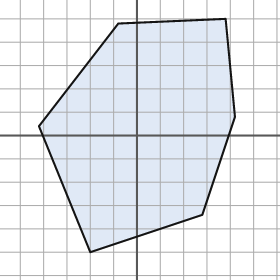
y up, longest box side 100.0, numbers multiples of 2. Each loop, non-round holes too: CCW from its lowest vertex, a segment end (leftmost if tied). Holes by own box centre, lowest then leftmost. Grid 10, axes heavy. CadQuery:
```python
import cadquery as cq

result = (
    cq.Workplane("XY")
    .moveTo(-20.0, -50.0)
    .lineTo(28.0, -34.0)
    .lineTo(42.0, 8.0)
    .lineTo(38.0, 50.0)
    .lineTo(-8.0, 48.0)
    .lineTo(-42.0, 4.0)
    .close()
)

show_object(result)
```